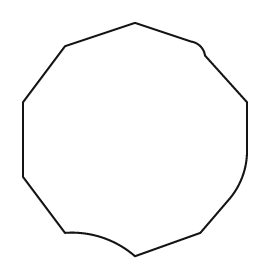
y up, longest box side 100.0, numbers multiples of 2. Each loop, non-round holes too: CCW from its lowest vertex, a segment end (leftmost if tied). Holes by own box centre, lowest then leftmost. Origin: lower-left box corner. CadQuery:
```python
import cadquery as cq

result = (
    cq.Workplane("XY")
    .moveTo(48.0, 0.0)
    .lineTo(76.0, 10.0)
    .lineTo(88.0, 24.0)
    .threePointArc((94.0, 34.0), (96.0, 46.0))
    .lineTo(96.0, 66.0)
    .lineTo(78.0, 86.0)
    .threePointArc((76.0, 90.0), (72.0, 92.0))
    .lineTo(48.0, 100.0)
    .lineTo(18.0, 90.0)
    .lineTo(0.0, 66.0)
    .lineTo(0.0, 34.0)
    .lineTo(18.0, 10.0)
    .threePointArc((34.0, 8.0), (48.0, 0.0))
    .close()
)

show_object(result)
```